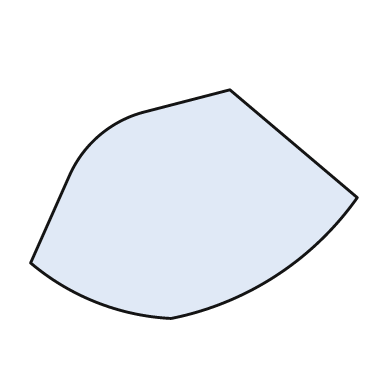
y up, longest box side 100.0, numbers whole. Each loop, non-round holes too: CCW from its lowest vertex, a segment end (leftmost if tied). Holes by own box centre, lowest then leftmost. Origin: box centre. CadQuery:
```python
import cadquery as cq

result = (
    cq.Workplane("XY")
    .moveTo(-7.0, -35.0)
    .threePointArc((25.0, -22.0), (50.0, 2.0))
    .lineTo(11.0, 35.0)
    .lineTo(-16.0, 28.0)
    .threePointArc((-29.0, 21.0), (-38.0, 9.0))
    .lineTo(-50.0, -18.0)
    .threePointArc((-30.0, -30.0), (-7.0, -35.0))
    .close()
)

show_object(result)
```